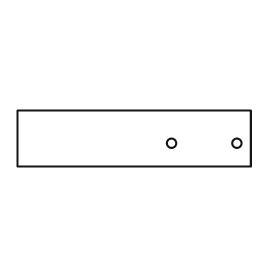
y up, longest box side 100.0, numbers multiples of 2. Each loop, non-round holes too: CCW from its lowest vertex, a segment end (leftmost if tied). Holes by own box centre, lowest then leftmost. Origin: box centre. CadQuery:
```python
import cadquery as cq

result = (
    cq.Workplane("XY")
    .moveTo(-50.0, -12.0)
    .lineTo(50.0, -12.0)
    .lineTo(50.0, 12.0)
    .lineTo(-50.0, 12.0)
    .close()
    .moveTo(16.0, -2.0)
    .circle(2.0)
    .moveTo(44.0, -2.0)
    .circle(2.0)
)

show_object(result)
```